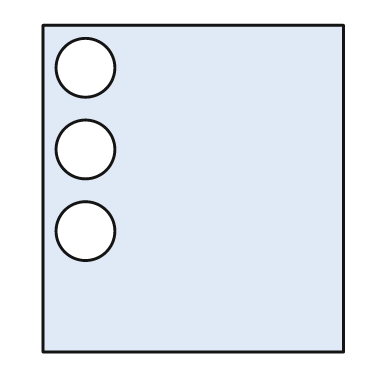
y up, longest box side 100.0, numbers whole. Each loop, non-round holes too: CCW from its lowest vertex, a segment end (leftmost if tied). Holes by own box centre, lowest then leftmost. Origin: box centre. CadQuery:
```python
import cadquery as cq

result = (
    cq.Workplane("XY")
    .moveTo(-46.0, -50.0)
    .lineTo(46.0, -50.0)
    .lineTo(46.0, 50.0)
    .lineTo(-46.0, 50.0)
    .close()
    .moveTo(-33.0, -13.0)
    .circle(9.0)
    .moveTo(-33.0, 12.0)
    .circle(9.0)
    .moveTo(-33.0, 37.0)
    .circle(9.0)
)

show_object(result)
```